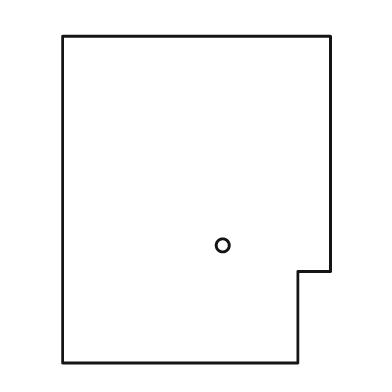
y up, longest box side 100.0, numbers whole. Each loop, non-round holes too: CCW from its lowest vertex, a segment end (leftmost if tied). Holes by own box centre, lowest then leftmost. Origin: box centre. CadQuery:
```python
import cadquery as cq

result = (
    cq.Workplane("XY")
    .moveTo(-41.0, -50.0)
    .lineTo(31.0, -50.0)
    .lineTo(31.0, -22.0)
    .lineTo(41.0, -22.0)
    .lineTo(41.0, 50.0)
    .lineTo(-41.0, 50.0)
    .close()
    .moveTo(8.0, -14.0)
    .circle(2.0)
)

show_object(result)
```